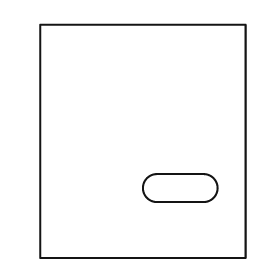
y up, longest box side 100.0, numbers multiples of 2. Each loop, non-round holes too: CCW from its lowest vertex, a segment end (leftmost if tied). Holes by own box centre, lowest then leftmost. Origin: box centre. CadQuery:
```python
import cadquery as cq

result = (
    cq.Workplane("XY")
    .moveTo(-44.0, -50.0)
    .lineTo(44.0, -50.0)
    .lineTo(44.0, 50.0)
    .lineTo(-44.0, 50.0)
    .close()
    .moveTo(6.0, -26.0)
    .lineTo(26.0, -26.0)
    .threePointArc((32.0, -20.0), (26.0, -14.0))
    .lineTo(6.0, -14.0)
    .threePointArc((0.0, -20.0), (6.0, -26.0))
    .close()
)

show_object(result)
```